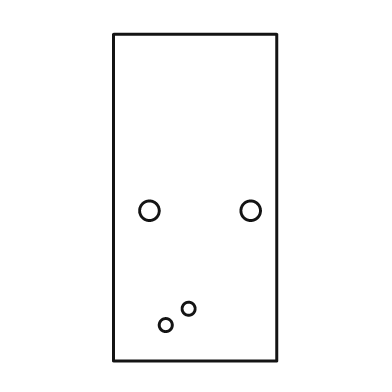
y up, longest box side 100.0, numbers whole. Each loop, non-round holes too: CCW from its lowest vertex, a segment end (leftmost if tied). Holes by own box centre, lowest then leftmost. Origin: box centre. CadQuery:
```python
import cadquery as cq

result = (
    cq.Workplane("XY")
    .moveTo(-25.0, -50.0)
    .lineTo(25.0, -50.0)
    .lineTo(25.0, 50.0)
    .lineTo(-25.0, 50.0)
    .close()
    .moveTo(-9.0, -39.0)
    .circle(2.0)
    .moveTo(-2.0, -34.0)
    .circle(2.0)
    .moveTo(-14.0, -4.0)
    .circle(3.0)
    .moveTo(17.0, -4.0)
    .circle(3.0)
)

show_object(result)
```